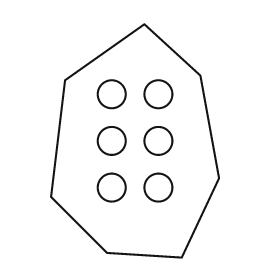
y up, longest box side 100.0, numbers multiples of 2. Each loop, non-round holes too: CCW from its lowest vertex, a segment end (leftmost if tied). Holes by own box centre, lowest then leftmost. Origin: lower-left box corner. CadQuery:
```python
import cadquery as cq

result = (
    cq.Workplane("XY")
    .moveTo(56.0, 0.0)
    .lineTo(72.0, 34.0)
    .lineTo(64.0, 78.0)
    .lineTo(40.0, 100.0)
    .lineTo(6.0, 76.0)
    .lineTo(0.0, 26.0)
    .lineTo(24.0, 2.0)
    .close()
    .moveTo(26.0, 30.0)
    .circle(6.0)
    .moveTo(46.0, 30.0)
    .circle(6.0)
    .moveTo(26.0, 50.0)
    .circle(6.0)
    .moveTo(46.0, 50.0)
    .circle(6.0)
    .moveTo(26.0, 70.0)
    .circle(6.0)
    .moveTo(46.0, 70.0)
    .circle(6.0)
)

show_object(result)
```